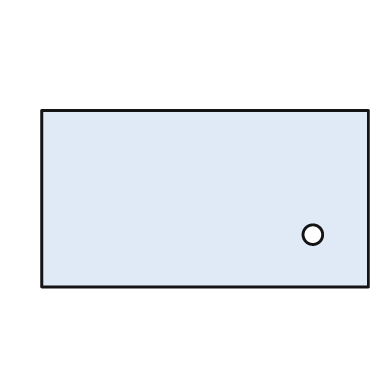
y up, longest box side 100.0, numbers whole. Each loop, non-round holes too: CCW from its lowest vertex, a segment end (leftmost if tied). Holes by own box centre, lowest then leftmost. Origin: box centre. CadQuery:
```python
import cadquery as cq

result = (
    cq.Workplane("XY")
    .moveTo(-50.0, -27.0)
    .lineTo(50.0, -27.0)
    .lineTo(50.0, 27.0)
    .lineTo(-50.0, 27.0)
    .close()
    .moveTo(33.0, -11.0)
    .circle(3.0)
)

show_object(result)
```